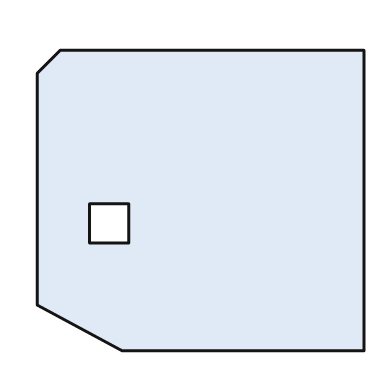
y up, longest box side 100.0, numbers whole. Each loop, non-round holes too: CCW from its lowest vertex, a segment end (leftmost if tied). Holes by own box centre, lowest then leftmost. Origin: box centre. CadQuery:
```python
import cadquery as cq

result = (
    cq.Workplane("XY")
    .moveTo(-24.0, -46.0)
    .lineTo(50.0, -46.0)
    .lineTo(50.0, 46.0)
    .lineTo(-43.0, 46.0)
    .lineTo(-50.0, 39.0)
    .lineTo(-50.0, -32.0)
    .close()
    .moveTo(-34.0, -13.0)
    .lineTo(-22.0, -13.0)
    .lineTo(-22.0, -1.0)
    .lineTo(-34.0, -1.0)
    .close()
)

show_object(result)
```